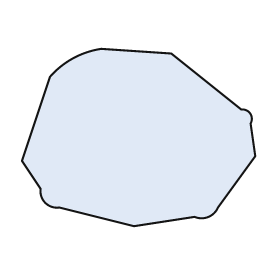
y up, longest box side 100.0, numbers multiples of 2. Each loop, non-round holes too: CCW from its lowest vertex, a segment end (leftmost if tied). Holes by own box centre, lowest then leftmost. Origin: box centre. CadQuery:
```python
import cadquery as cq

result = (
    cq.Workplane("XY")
    .moveTo(-2.0, -38.0)
    .lineTo(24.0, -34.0)
    .threePointArc((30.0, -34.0), (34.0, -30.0))
    .lineTo(50.0, -8.0)
    .lineTo(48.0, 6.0)
    .threePointArc((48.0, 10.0), (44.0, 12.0))
    .lineTo(14.0, 36.0)
    .lineTo(-16.0, 38.0)
    .threePointArc((-28.0, 34.0), (-38.0, 26.0))
    .lineTo(-50.0, -10.0)
    .lineTo(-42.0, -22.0)
    .threePointArc((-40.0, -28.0), (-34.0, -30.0))
    .close()
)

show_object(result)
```